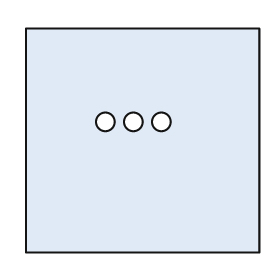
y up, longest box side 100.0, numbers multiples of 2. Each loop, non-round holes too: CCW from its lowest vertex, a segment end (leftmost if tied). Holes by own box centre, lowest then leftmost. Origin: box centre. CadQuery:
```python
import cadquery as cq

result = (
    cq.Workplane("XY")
    .moveTo(-50.0, -48.0)
    .lineTo(50.0, -48.0)
    .lineTo(50.0, 48.0)
    .lineTo(-50.0, 48.0)
    .close()
    .moveTo(-16.0, 8.0)
    .circle(4.0)
    .moveTo(-4.0, 8.0)
    .circle(4.0)
    .moveTo(8.0, 8.0)
    .circle(4.0)
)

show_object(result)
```